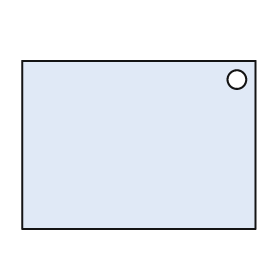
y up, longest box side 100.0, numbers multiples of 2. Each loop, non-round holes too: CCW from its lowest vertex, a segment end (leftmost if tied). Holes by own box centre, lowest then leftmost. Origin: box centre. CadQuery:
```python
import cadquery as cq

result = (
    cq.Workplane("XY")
    .moveTo(-50.0, -36.0)
    .lineTo(50.0, -36.0)
    .lineTo(50.0, 36.0)
    .lineTo(-50.0, 36.0)
    .close()
    .moveTo(42.0, 28.0)
    .circle(4.0)
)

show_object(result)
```